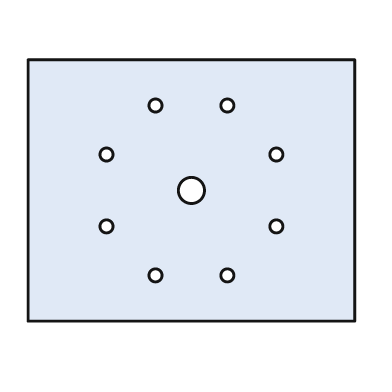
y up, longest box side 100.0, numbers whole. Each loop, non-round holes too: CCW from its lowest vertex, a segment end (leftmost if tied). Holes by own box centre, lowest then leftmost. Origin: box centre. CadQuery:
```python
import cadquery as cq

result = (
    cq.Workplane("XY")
    .moveTo(-50.0, -40.0)
    .lineTo(50.0, -40.0)
    .lineTo(50.0, 40.0)
    .lineTo(-50.0, 40.0)
    .close()
    .moveTo(-11.0, -26.0)
    .circle(2.0)
    .moveTo(11.0, -26.0)
    .circle(2.0)
    .moveTo(-26.0, -11.0)
    .circle(2.0)
    .moveTo(26.0, -11.0)
    .circle(2.0)
    .moveTo(0.0, 0.0)
    .circle(4.0)
    .moveTo(-26.0, 11.0)
    .circle(2.0)
    .moveTo(26.0, 11.0)
    .circle(2.0)
    .moveTo(-11.0, 26.0)
    .circle(2.0)
    .moveTo(11.0, 26.0)
    .circle(2.0)
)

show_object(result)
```